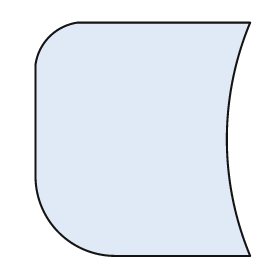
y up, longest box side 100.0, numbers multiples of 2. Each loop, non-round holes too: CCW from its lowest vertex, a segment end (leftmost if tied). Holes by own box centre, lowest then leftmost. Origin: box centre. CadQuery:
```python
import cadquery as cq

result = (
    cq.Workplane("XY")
    .moveTo(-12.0, -50.0)
    .lineTo(46.0, -50.0)
    .threePointArc((36.0, 0.0), (46.0, 50.0))
    .lineTo(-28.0, 50.0)
    .threePointArc((-40.0, 44.0), (-46.0, 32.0))
    .lineTo(-46.0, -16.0)
    .threePointArc((-36.0, -40.0), (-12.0, -50.0))
    .close()
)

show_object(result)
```